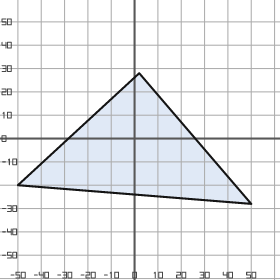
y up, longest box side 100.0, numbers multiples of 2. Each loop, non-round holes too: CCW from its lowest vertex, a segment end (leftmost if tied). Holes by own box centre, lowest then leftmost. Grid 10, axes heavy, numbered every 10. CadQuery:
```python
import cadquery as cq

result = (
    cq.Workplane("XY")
    .moveTo(50.0, -28.0)
    .lineTo(2.0, 28.0)
    .lineTo(-50.0, -20.0)
    .close()
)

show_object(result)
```